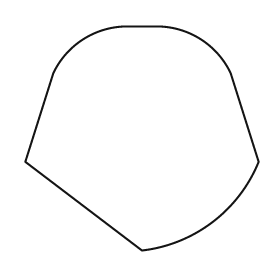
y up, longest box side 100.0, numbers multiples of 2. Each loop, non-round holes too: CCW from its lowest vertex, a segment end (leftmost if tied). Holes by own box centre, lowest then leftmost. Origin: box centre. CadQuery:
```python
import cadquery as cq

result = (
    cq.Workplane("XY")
    .moveTo(0.0, -48.0)
    .threePointArc((30.0, -36.0), (50.0, -10.0))
    .lineTo(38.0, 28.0)
    .threePointArc((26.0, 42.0), (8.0, 48.0))
    .lineTo(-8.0, 48.0)
    .threePointArc((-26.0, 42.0), (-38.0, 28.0))
    .lineTo(-50.0, -10.0)
    .close()
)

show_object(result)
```